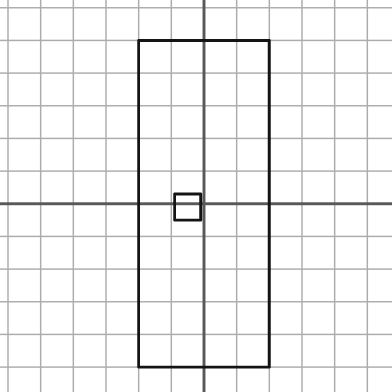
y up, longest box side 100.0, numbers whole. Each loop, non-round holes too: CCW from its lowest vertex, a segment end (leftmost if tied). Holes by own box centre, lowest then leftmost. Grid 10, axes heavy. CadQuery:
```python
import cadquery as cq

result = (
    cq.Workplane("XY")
    .moveTo(-20.0, -50.0)
    .lineTo(20.0, -50.0)
    .lineTo(20.0, 50.0)
    .lineTo(-20.0, 50.0)
    .close()
    .moveTo(-9.0, -5.0)
    .lineTo(-1.0, -5.0)
    .lineTo(-1.0, 3.0)
    .lineTo(-9.0, 3.0)
    .close()
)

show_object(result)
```